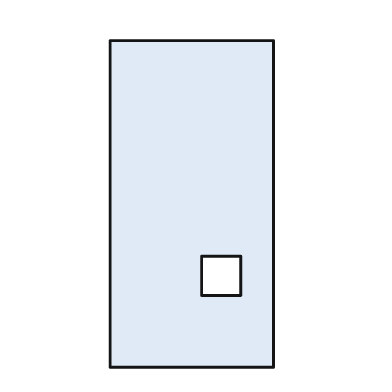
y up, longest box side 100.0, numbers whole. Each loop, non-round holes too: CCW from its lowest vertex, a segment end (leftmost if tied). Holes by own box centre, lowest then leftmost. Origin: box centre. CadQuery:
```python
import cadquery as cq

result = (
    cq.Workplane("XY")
    .moveTo(-25.0, -50.0)
    .lineTo(25.0, -50.0)
    .lineTo(25.0, 50.0)
    .lineTo(-25.0, 50.0)
    .close()
    .moveTo(3.0, -28.0)
    .lineTo(15.0, -28.0)
    .lineTo(15.0, -16.0)
    .lineTo(3.0, -16.0)
    .close()
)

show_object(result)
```